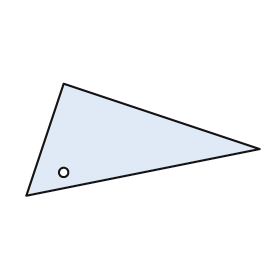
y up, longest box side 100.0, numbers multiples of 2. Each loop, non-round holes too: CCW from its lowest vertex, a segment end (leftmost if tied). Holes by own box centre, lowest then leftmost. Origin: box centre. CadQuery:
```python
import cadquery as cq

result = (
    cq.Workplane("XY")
    .moveTo(-50.0, -24.0)
    .lineTo(50.0, -4.0)
    .lineTo(-34.0, 24.0)
    .close()
    .moveTo(-34.0, -14.0)
    .circle(2.0)
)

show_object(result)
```